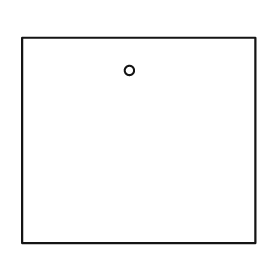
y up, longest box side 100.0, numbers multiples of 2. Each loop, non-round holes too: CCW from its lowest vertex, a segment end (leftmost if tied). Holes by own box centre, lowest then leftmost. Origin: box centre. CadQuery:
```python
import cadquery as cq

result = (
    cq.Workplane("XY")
    .moveTo(-50.0, -44.0)
    .lineTo(50.0, -44.0)
    .lineTo(50.0, 44.0)
    .lineTo(-50.0, 44.0)
    .close()
    .moveTo(-4.0, 30.0)
    .circle(2.0)
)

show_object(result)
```